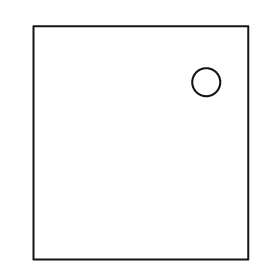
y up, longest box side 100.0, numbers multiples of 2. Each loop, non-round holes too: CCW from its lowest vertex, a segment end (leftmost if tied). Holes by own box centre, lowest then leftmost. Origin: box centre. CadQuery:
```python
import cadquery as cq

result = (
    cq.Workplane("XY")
    .moveTo(-46.0, -50.0)
    .lineTo(46.0, -50.0)
    .lineTo(46.0, 50.0)
    .lineTo(-46.0, 50.0)
    .close()
    .moveTo(28.0, 26.0)
    .circle(6.0)
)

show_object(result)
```